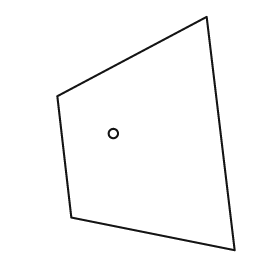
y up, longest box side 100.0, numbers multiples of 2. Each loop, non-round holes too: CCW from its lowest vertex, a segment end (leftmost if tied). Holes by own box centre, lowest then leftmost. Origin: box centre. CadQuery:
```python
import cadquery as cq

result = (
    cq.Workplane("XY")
    .moveTo(38.0, -50.0)
    .lineTo(26.0, 50.0)
    .lineTo(-38.0, 16.0)
    .lineTo(-32.0, -36.0)
    .close()
    .moveTo(-14.0, 0.0)
    .circle(2.0)
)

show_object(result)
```